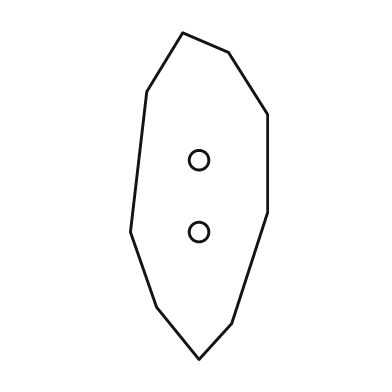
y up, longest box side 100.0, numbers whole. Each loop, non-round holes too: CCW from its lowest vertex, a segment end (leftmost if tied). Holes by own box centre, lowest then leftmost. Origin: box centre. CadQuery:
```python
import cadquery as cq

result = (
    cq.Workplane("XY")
    .moveTo(0.0, -50.0)
    .lineTo(10.0, -39.0)
    .lineTo(21.0, -5.0)
    .lineTo(21.0, 25.0)
    .lineTo(9.0, 44.0)
    .lineTo(-5.0, 50.0)
    .lineTo(-16.0, 32.0)
    .lineTo(-21.0, -11.0)
    .lineTo(-13.0, -34.0)
    .close()
    .moveTo(0.0, -11.0)
    .circle(3.0)
    .moveTo(0.0, 11.0)
    .circle(3.0)
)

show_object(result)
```